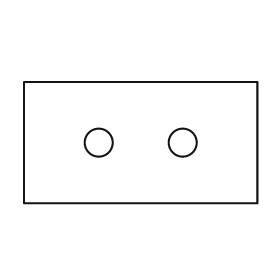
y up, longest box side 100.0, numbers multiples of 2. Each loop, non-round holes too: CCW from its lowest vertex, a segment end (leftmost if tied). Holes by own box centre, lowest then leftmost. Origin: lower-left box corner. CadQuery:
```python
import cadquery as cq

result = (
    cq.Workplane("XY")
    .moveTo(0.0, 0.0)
    .lineTo(100.0, 0.0)
    .lineTo(100.0, 52.0)
    .lineTo(0.0, 52.0)
    .close()
    .moveTo(32.0, 26.0)
    .circle(6.0)
    .moveTo(68.0, 26.0)
    .circle(6.0)
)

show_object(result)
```